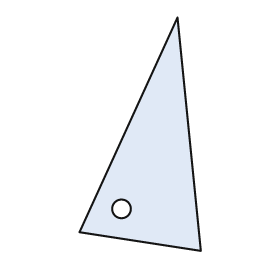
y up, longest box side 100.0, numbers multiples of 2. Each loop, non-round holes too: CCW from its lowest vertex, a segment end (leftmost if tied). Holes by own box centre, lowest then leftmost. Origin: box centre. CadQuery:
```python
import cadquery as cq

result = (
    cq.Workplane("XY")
    .moveTo(26.0, -50.0)
    .lineTo(16.0, 50.0)
    .lineTo(-26.0, -42.0)
    .close()
    .moveTo(-8.0, -32.0)
    .circle(4.0)
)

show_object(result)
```